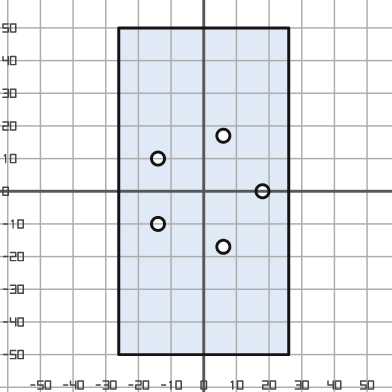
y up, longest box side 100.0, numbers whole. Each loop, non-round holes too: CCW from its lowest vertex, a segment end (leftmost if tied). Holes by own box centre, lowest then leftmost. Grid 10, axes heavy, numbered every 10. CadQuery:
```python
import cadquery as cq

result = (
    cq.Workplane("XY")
    .moveTo(-26.0, -50.0)
    .lineTo(26.0, -50.0)
    .lineTo(26.0, 50.0)
    .lineTo(-26.0, 50.0)
    .close()
    .moveTo(6.0, -17.0)
    .circle(2.0)
    .moveTo(-14.0, -10.0)
    .circle(2.0)
    .moveTo(18.0, 0.0)
    .circle(2.0)
    .moveTo(-14.0, 10.0)
    .circle(2.0)
    .moveTo(6.0, 17.0)
    .circle(2.0)
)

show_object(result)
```